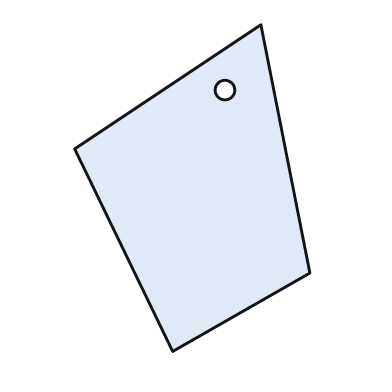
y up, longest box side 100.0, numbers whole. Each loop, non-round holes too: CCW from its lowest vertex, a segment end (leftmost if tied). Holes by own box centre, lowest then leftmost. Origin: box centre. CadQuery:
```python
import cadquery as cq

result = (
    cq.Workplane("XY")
    .moveTo(-6.0, -50.0)
    .lineTo(36.0, -26.0)
    .lineTo(21.0, 50.0)
    .lineTo(-36.0, 12.0)
    .close()
    .moveTo(10.0, 30.0)
    .circle(3.0)
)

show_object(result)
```